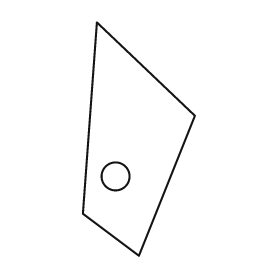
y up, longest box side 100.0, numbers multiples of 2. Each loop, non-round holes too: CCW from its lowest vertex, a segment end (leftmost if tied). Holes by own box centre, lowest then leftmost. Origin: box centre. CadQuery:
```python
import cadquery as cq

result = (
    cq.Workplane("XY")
    .moveTo(0.0, -50.0)
    .lineTo(24.0, 10.0)
    .lineTo(-18.0, 50.0)
    .lineTo(-24.0, -32.0)
    .close()
    .moveTo(-10.0, -16.0)
    .circle(6.0)
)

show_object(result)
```